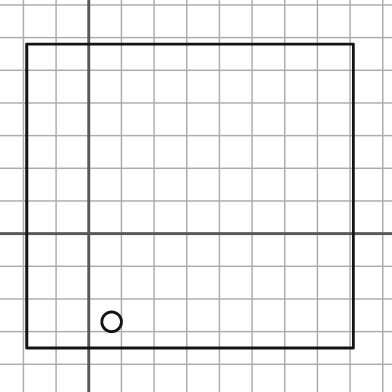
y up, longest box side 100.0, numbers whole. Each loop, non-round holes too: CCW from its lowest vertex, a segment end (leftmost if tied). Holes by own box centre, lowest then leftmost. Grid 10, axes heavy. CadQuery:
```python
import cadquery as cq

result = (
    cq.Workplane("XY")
    .moveTo(-19.0, -35.0)
    .lineTo(81.0, -35.0)
    .lineTo(81.0, 58.0)
    .lineTo(-19.0, 58.0)
    .close()
    .moveTo(7.0, -27.0)
    .circle(3.0)
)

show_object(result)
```